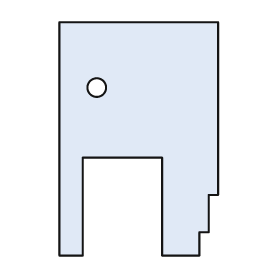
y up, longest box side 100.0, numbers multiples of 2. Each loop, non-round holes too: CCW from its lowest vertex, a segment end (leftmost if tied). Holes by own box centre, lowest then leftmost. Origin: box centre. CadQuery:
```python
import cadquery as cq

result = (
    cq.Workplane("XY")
    .moveTo(-34.0, -50.0)
    .lineTo(-24.0, -50.0)
    .lineTo(-24.0, -8.0)
    .lineTo(10.0, -8.0)
    .lineTo(10.0, -50.0)
    .lineTo(26.0, -50.0)
    .lineTo(26.0, -40.0)
    .lineTo(30.0, -40.0)
    .lineTo(30.0, -24.0)
    .lineTo(34.0, -24.0)
    .lineTo(34.0, 50.0)
    .lineTo(-34.0, 50.0)
    .close()
    .moveTo(-18.0, 22.0)
    .circle(4.0)
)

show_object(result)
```